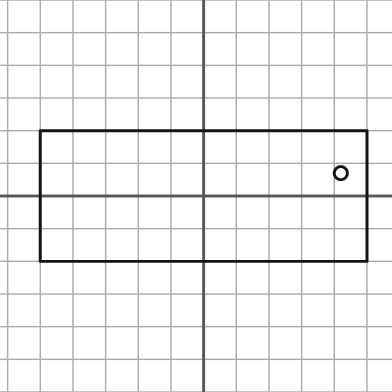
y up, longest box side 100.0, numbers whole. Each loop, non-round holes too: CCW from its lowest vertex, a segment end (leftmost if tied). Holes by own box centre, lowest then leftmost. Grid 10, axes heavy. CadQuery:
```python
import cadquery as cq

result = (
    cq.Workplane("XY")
    .moveTo(-50.0, -20.0)
    .lineTo(50.0, -20.0)
    .lineTo(50.0, 20.0)
    .lineTo(-50.0, 20.0)
    .close()
    .moveTo(42.0, 7.0)
    .circle(2.0)
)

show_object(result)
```